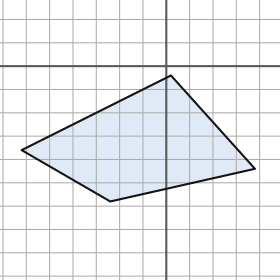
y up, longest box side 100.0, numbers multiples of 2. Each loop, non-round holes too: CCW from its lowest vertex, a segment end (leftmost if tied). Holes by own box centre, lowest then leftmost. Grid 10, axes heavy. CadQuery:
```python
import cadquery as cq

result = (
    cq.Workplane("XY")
    .moveTo(-24.0, -58.0)
    .lineTo(38.0, -44.0)
    .lineTo(2.0, -4.0)
    .lineTo(-62.0, -36.0)
    .close()
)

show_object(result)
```